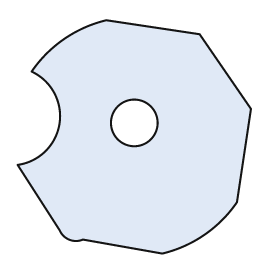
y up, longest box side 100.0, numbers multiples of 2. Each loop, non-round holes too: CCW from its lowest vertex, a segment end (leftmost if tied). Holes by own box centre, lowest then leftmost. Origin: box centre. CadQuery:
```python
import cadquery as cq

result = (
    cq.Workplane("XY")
    .moveTo(12.0, -50.0)
    .threePointArc((30.0, -42.0), (44.0, -28.0))
    .lineTo(50.0, 12.0)
    .lineTo(28.0, 44.0)
    .lineTo(-12.0, 50.0)
    .threePointArc((-30.0, 42.0), (-44.0, 28.0))
    .threePointArc((-32.0, 6.0), (-50.0, -12.0))
    .lineTo(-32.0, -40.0)
    .threePointArc((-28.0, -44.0), (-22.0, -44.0))
    .close()
    .moveTo(0.0, 6.0)
    .circle(10.0)
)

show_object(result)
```